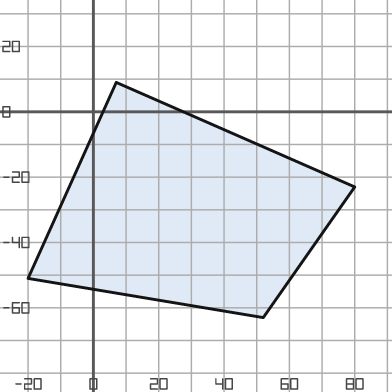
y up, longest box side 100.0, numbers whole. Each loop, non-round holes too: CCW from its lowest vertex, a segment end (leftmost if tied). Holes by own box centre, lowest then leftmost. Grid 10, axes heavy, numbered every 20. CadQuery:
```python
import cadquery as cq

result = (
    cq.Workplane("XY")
    .moveTo(52.0, -63.0)
    .lineTo(80.0, -23.0)
    .lineTo(7.0, 9.0)
    .lineTo(-20.0, -51.0)
    .close()
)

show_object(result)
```